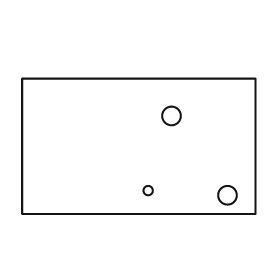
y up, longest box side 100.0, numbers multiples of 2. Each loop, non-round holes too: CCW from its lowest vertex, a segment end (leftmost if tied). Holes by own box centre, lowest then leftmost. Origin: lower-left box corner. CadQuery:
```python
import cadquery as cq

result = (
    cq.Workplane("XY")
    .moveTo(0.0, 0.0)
    .lineTo(100.0, 0.0)
    .lineTo(100.0, 58.0)
    .lineTo(0.0, 58.0)
    .close()
    .moveTo(88.0, 8.0)
    .circle(4.0)
    .moveTo(54.0, 10.0)
    .circle(2.0)
    .moveTo(64.0, 42.0)
    .circle(4.0)
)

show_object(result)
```